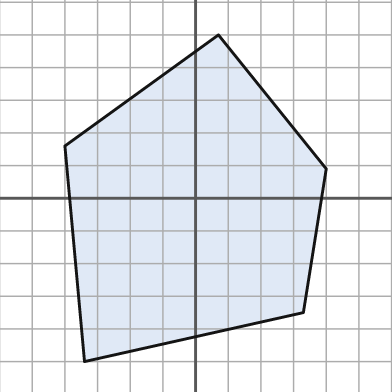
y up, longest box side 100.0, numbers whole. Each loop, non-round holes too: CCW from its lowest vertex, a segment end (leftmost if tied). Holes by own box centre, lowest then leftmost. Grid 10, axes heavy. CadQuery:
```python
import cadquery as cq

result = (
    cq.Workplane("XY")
    .moveTo(-34.0, -50.0)
    .lineTo(33.0, -35.0)
    .lineTo(40.0, 9.0)
    .lineTo(7.0, 50.0)
    .lineTo(-40.0, 16.0)
    .close()
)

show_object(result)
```